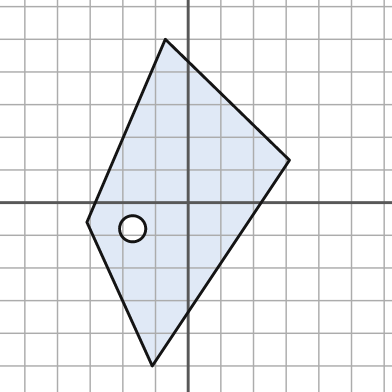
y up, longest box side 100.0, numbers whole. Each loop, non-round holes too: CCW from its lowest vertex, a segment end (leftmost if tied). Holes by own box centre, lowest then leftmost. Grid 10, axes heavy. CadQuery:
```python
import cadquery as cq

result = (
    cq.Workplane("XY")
    .moveTo(-11.0, -50.0)
    .lineTo(31.0, 13.0)
    .lineTo(-7.0, 50.0)
    .lineTo(-31.0, -6.0)
    .close()
    .moveTo(-17.0, -8.0)
    .circle(4.0)
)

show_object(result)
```